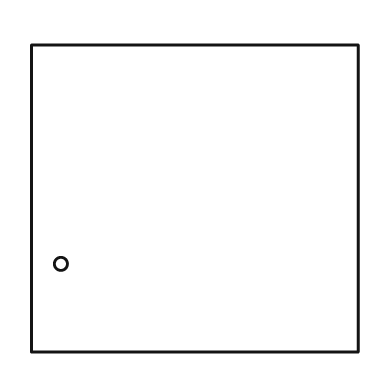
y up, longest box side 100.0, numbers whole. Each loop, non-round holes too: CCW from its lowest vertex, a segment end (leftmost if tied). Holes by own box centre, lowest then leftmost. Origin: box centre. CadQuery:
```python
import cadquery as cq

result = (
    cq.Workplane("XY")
    .moveTo(-50.0, -47.0)
    .lineTo(50.0, -47.0)
    .lineTo(50.0, 47.0)
    .lineTo(-50.0, 47.0)
    .close()
    .moveTo(-41.0, -20.0)
    .circle(2.0)
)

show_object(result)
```